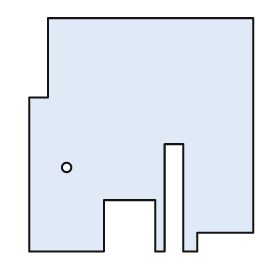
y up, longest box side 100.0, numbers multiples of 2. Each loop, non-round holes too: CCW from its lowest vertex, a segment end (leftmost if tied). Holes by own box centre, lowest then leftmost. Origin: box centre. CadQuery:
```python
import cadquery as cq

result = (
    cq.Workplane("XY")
    .moveTo(-48.0, -50.0)
    .lineTo(-16.0, -50.0)
    .lineTo(-16.0, -28.0)
    .lineTo(6.0, -28.0)
    .lineTo(6.0, -50.0)
    .lineTo(10.0, -50.0)
    .lineTo(10.0, -4.0)
    .lineTo(18.0, -4.0)
    .lineTo(18.0, -50.0)
    .lineTo(24.0, -50.0)
    .lineTo(24.0, -42.0)
    .lineTo(48.0, -42.0)
    .lineTo(48.0, 50.0)
    .lineTo(-40.0, 50.0)
    .lineTo(-40.0, 16.0)
    .lineTo(-48.0, 16.0)
    .close()
    .moveTo(-32.0, -14.0)
    .circle(2.0)
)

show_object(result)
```